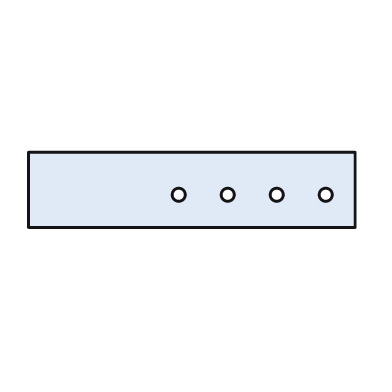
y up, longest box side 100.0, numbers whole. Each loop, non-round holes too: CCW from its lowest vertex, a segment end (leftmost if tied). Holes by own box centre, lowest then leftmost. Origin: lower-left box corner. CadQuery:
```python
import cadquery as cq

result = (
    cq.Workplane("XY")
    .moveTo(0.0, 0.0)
    .lineTo(100.0, 0.0)
    .lineTo(100.0, 23.0)
    .lineTo(0.0, 23.0)
    .close()
    .moveTo(46.0, 10.0)
    .circle(2.0)
    .moveTo(61.0, 10.0)
    .circle(2.0)
    .moveTo(76.0, 10.0)
    .circle(2.0)
    .moveTo(91.0, 10.0)
    .circle(2.0)
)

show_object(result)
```